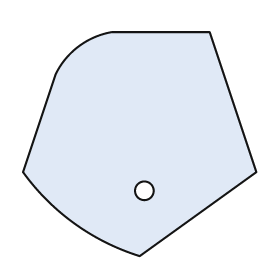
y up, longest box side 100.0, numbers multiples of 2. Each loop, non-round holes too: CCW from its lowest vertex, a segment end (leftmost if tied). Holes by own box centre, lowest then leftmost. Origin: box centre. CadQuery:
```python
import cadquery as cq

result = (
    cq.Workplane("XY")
    .moveTo(0.0, -48.0)
    .lineTo(50.0, -12.0)
    .lineTo(30.0, 48.0)
    .lineTo(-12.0, 48.0)
    .threePointArc((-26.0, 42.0), (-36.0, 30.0))
    .lineTo(-50.0, -12.0)
    .threePointArc((-28.0, -34.0), (0.0, -48.0))
    .close()
    .moveTo(2.0, -20.0)
    .circle(4.0)
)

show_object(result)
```